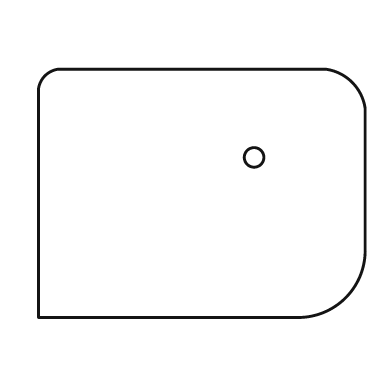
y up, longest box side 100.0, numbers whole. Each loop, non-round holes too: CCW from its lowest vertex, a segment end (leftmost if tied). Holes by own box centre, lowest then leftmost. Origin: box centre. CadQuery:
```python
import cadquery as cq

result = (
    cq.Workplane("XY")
    .moveTo(-50.0, -38.0)
    .lineTo(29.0, -38.0)
    .threePointArc((44.0, -32.0), (50.0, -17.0))
    .lineTo(50.0, 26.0)
    .threePointArc((46.0, 34.0), (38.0, 38.0))
    .lineTo(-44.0, 38.0)
    .threePointArc((-48.0, 36.0), (-50.0, 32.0))
    .close()
    .moveTo(16.0, 11.0)
    .circle(3.0)
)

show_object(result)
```